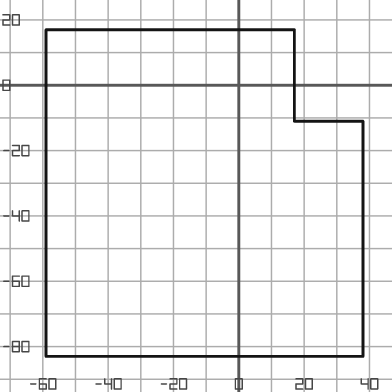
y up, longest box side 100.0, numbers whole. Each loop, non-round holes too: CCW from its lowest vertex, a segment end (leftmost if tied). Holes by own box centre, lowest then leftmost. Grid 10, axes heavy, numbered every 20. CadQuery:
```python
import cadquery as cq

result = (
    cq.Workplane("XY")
    .moveTo(-59.0, -83.0)
    .lineTo(38.0, -83.0)
    .lineTo(38.0, -11.0)
    .lineTo(17.0, -11.0)
    .lineTo(17.0, 17.0)
    .lineTo(-59.0, 17.0)
    .close()
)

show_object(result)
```